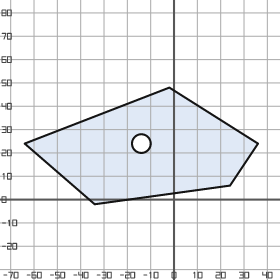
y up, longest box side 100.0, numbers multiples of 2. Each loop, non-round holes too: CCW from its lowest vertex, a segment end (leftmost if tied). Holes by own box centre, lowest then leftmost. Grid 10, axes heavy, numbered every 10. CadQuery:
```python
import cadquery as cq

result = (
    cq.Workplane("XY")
    .moveTo(-34.0, -2.0)
    .lineTo(24.0, 6.0)
    .lineTo(36.0, 24.0)
    .lineTo(-2.0, 48.0)
    .lineTo(-64.0, 24.0)
    .close()
    .moveTo(-14.0, 24.0)
    .circle(4.0)
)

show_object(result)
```